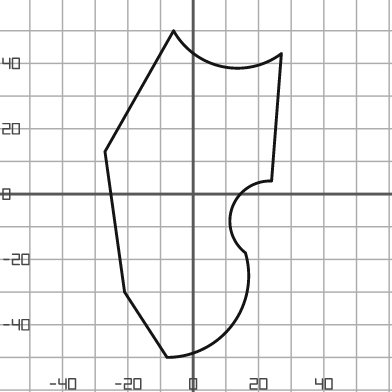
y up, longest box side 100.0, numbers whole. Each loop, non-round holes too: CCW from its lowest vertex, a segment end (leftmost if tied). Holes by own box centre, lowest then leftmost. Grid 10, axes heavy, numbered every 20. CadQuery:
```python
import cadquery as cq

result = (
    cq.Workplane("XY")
    .moveTo(-8.0, -50.0)
    .threePointArc((12.0, -40.0), (16.0, -18.0))
    .threePointArc((12.0, -4.0), (24.0, 4.0))
    .lineTo(27.0, 43.0)
    .threePointArc((9.0, 39.0), (-6.0, 50.0))
    .lineTo(-27.0, 13.0)
    .lineTo(-21.0, -30.0)
    .close()
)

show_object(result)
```